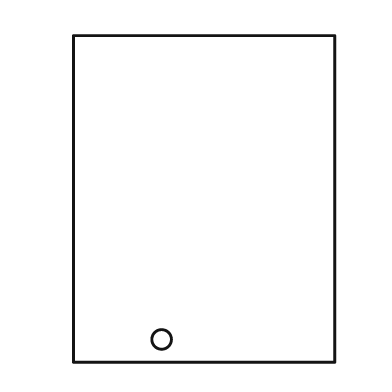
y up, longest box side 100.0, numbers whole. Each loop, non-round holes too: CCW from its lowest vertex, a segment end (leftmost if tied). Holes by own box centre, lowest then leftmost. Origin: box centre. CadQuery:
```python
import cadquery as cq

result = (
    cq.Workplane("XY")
    .moveTo(-40.0, -50.0)
    .lineTo(40.0, -50.0)
    .lineTo(40.0, 50.0)
    .lineTo(-40.0, 50.0)
    .close()
    .moveTo(-13.0, -43.0)
    .circle(3.0)
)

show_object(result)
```